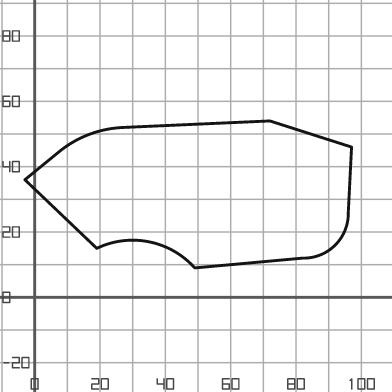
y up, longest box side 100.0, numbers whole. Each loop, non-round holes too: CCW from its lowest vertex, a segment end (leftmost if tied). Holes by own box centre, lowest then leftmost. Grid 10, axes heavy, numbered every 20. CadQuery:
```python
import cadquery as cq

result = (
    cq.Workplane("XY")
    .moveTo(49.0, 9.0)
    .lineTo(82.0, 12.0)
    .threePointArc((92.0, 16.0), (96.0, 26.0))
    .lineTo(97.0, 46.0)
    .lineTo(72.0, 54.0)
    .lineTo(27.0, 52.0)
    .threePointArc((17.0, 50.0), (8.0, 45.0))
    .lineTo(-3.0, 36.0)
    .lineTo(19.0, 15.0)
    .threePointArc((35.0, 17.0), (49.0, 9.0))
    .close()
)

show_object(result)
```